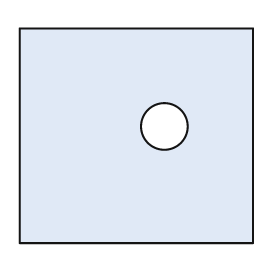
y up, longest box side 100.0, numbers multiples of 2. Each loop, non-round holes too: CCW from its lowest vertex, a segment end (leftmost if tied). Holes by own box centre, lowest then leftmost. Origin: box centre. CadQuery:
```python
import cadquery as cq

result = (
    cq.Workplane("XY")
    .moveTo(-50.0, -46.0)
    .lineTo(50.0, -46.0)
    .lineTo(50.0, 46.0)
    .lineTo(-50.0, 46.0)
    .close()
    .moveTo(12.0, 4.0)
    .circle(10.0)
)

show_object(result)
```